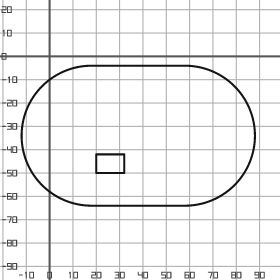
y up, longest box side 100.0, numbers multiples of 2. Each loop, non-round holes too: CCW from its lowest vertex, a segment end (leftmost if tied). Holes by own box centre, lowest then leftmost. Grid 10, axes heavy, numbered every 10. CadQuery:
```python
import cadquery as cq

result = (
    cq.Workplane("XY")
    .moveTo(18.0, -64.0)
    .lineTo(58.0, -64.0)
    .threePointArc((88.0, -34.0), (58.0, -4.0))
    .lineTo(18.0, -4.0)
    .threePointArc((-12.0, -34.0), (18.0, -64.0))
    .close()
    .moveTo(20.0, -50.0)
    .lineTo(32.0, -50.0)
    .lineTo(32.0, -42.0)
    .lineTo(20.0, -42.0)
    .close()
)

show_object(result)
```